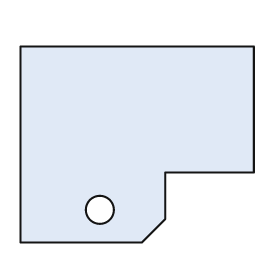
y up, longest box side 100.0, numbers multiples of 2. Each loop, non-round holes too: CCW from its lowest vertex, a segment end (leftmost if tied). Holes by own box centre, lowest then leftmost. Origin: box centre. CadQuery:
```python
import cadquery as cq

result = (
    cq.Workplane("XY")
    .moveTo(-50.0, -42.0)
    .lineTo(2.0, -42.0)
    .lineTo(12.0, -32.0)
    .lineTo(12.0, -12.0)
    .lineTo(50.0, -12.0)
    .lineTo(50.0, 42.0)
    .lineTo(-50.0, 42.0)
    .close()
    .moveTo(-16.0, -28.0)
    .circle(6.0)
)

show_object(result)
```